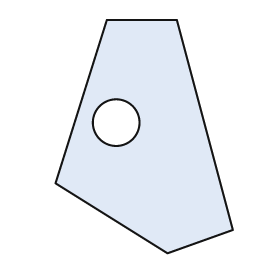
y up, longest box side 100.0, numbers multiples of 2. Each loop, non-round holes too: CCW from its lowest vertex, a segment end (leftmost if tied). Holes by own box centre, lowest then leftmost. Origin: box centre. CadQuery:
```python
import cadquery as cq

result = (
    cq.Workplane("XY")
    .moveTo(10.0, -50.0)
    .lineTo(38.0, -40.0)
    .lineTo(14.0, 50.0)
    .lineTo(-16.0, 50.0)
    .lineTo(-38.0, -20.0)
    .close()
    .moveTo(-12.0, 6.0)
    .circle(10.0)
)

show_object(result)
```